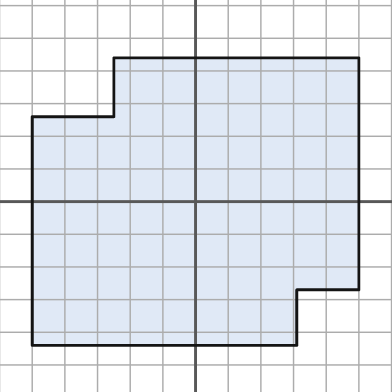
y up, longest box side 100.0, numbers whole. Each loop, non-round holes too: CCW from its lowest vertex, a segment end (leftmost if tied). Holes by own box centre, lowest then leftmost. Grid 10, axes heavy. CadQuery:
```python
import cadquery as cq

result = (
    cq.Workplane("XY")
    .moveTo(-50.0, -44.0)
    .lineTo(31.0, -44.0)
    .lineTo(31.0, -27.0)
    .lineTo(50.0, -27.0)
    .lineTo(50.0, 44.0)
    .lineTo(-25.0, 44.0)
    .lineTo(-25.0, 26.0)
    .lineTo(-50.0, 26.0)
    .close()
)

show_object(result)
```